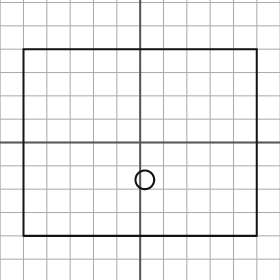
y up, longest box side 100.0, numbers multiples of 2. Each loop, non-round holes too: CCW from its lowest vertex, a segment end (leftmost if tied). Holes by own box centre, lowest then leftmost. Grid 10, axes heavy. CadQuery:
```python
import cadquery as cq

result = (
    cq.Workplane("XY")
    .moveTo(-50.0, -40.0)
    .lineTo(50.0, -40.0)
    .lineTo(50.0, 40.0)
    .lineTo(-50.0, 40.0)
    .close()
    .moveTo(2.0, -16.0)
    .circle(4.0)
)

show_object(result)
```